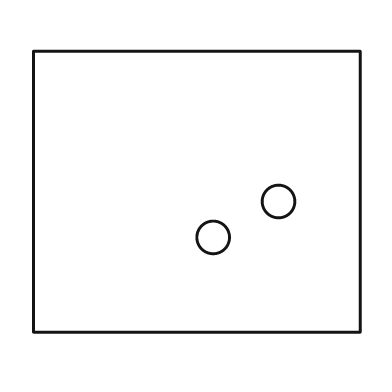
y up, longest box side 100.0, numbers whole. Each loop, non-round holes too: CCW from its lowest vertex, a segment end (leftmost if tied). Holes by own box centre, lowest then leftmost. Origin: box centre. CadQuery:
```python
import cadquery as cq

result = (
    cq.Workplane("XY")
    .moveTo(-50.0, -43.0)
    .lineTo(50.0, -43.0)
    .lineTo(50.0, 43.0)
    .lineTo(-50.0, 43.0)
    .close()
    .moveTo(5.0, -14.0)
    .circle(5.0)
    .moveTo(25.0, -3.0)
    .circle(5.0)
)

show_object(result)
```